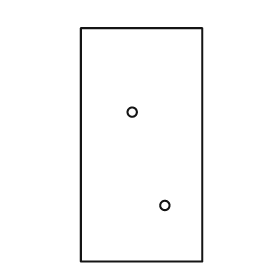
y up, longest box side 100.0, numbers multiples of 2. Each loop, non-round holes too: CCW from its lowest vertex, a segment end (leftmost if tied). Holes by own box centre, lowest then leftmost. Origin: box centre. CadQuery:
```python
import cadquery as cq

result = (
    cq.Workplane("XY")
    .moveTo(-26.0, -50.0)
    .lineTo(26.0, -50.0)
    .lineTo(26.0, 50.0)
    .lineTo(-26.0, 50.0)
    .close()
    .moveTo(10.0, -26.0)
    .circle(2.0)
    .moveTo(-4.0, 14.0)
    .circle(2.0)
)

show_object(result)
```